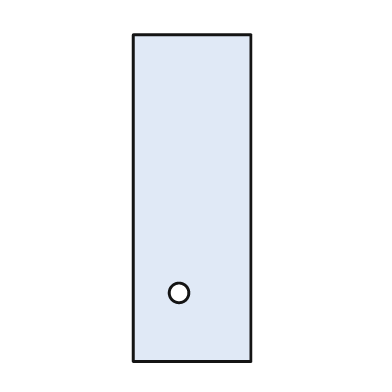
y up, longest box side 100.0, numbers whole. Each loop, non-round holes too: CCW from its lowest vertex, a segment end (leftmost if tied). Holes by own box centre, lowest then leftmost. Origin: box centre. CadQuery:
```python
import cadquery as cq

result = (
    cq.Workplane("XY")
    .moveTo(-18.0, -50.0)
    .lineTo(18.0, -50.0)
    .lineTo(18.0, 50.0)
    .lineTo(-18.0, 50.0)
    .close()
    .moveTo(-4.0, -29.0)
    .circle(3.0)
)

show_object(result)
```